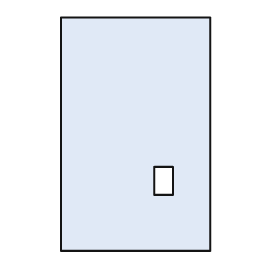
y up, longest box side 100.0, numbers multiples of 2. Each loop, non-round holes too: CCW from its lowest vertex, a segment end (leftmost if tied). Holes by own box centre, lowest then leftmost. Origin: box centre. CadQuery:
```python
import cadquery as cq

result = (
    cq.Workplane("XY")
    .moveTo(-32.0, -50.0)
    .lineTo(32.0, -50.0)
    .lineTo(32.0, 50.0)
    .lineTo(-32.0, 50.0)
    .close()
    .moveTo(8.0, -26.0)
    .lineTo(16.0, -26.0)
    .lineTo(16.0, -14.0)
    .lineTo(8.0, -14.0)
    .close()
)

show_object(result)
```